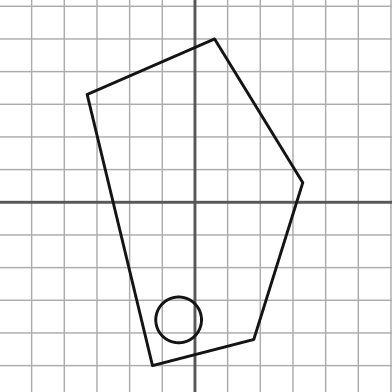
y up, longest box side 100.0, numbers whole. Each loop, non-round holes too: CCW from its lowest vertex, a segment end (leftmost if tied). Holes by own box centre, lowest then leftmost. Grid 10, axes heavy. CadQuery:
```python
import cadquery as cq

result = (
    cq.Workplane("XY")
    .moveTo(-13.0, -50.0)
    .lineTo(18.0, -42.0)
    .lineTo(33.0, 6.0)
    .lineTo(6.0, 50.0)
    .lineTo(-33.0, 33.0)
    .close()
    .moveTo(-5.0, -36.0)
    .circle(7.0)
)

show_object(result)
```